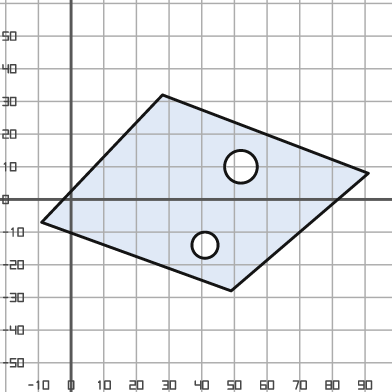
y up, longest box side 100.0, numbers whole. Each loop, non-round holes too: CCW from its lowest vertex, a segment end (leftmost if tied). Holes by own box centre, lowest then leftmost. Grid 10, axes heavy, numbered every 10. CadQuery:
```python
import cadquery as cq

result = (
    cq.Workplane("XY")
    .moveTo(49.0, -28.0)
    .lineTo(91.0, 8.0)
    .lineTo(28.0, 32.0)
    .lineTo(-9.0, -7.0)
    .close()
    .moveTo(41.0, -14.0)
    .circle(4.0)
    .moveTo(52.0, 10.0)
    .circle(5.0)
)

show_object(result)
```